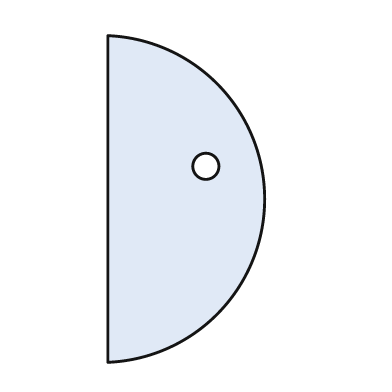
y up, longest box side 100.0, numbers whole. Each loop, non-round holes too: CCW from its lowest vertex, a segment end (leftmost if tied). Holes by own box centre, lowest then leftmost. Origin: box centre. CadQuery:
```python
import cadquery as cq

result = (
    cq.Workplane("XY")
    .moveTo(-24.0, -50.0)
    .threePointArc((24.0, 0.0), (-24.0, 50.0))
    .close()
    .moveTo(6.0, 10.0)
    .circle(4.0)
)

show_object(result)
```